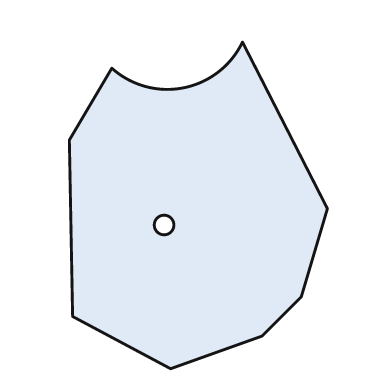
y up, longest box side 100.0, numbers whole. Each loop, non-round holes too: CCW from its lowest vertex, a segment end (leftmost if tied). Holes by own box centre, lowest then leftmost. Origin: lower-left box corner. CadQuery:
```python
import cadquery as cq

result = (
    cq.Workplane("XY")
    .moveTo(31.0, 0.0)
    .lineTo(59.0, 10.0)
    .lineTo(71.0, 22.0)
    .lineTo(79.0, 49.0)
    .lineTo(53.0, 100.0)
    .threePointArc((35.0, 86.0), (13.0, 92.0))
    .lineTo(0.0, 70.0)
    .lineTo(1.0, 16.0)
    .close()
    .moveTo(29.0, 44.0)
    .circle(3.0)
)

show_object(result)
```